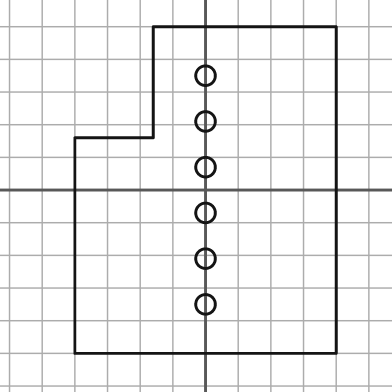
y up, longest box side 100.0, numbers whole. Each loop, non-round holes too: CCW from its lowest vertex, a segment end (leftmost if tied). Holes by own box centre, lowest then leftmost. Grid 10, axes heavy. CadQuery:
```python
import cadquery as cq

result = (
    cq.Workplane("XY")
    .moveTo(-40.0, -50.0)
    .lineTo(40.0, -50.0)
    .lineTo(40.0, 50.0)
    .lineTo(-16.0, 50.0)
    .lineTo(-16.0, 16.0)
    .lineTo(-40.0, 16.0)
    .close()
    .moveTo(0.0, -35.0)
    .circle(3.0)
    .moveTo(0.0, -21.0)
    .circle(3.0)
    .moveTo(0.0, -7.0)
    .circle(3.0)
    .moveTo(0.0, 7.0)
    .circle(3.0)
    .moveTo(0.0, 21.0)
    .circle(3.0)
    .moveTo(0.0, 35.0)
    .circle(3.0)
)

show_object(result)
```